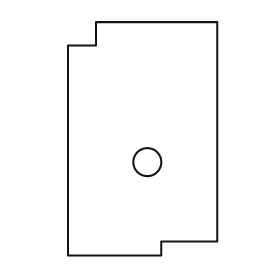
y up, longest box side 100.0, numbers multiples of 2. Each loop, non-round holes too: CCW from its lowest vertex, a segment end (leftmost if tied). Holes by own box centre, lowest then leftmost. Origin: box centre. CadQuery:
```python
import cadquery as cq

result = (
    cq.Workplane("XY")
    .moveTo(-32.0, -50.0)
    .lineTo(8.0, -50.0)
    .lineTo(8.0, -44.0)
    .lineTo(32.0, -44.0)
    .lineTo(32.0, 50.0)
    .lineTo(-20.0, 50.0)
    .lineTo(-20.0, 40.0)
    .lineTo(-32.0, 40.0)
    .close()
    .moveTo(2.0, -10.0)
    .circle(6.0)
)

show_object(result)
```